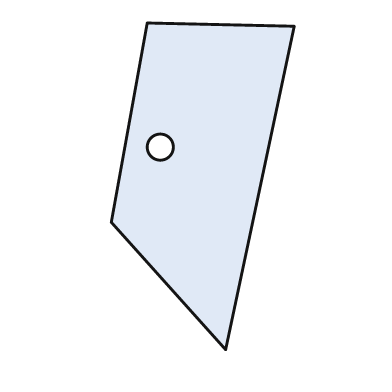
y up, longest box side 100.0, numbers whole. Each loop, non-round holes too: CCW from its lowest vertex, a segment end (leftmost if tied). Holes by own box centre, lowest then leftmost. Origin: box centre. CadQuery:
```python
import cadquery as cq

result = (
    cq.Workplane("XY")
    .moveTo(7.0, -50.0)
    .lineTo(28.0, 49.0)
    .lineTo(-17.0, 50.0)
    .lineTo(-28.0, -11.0)
    .close()
    .moveTo(-13.0, 12.0)
    .circle(4.0)
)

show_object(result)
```